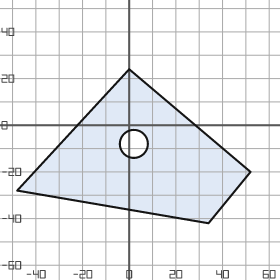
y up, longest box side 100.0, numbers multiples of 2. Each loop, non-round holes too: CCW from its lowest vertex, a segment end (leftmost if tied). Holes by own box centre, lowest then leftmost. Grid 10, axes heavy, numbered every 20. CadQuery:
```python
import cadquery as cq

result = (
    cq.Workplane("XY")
    .moveTo(34.0, -42.0)
    .lineTo(52.0, -20.0)
    .lineTo(0.0, 24.0)
    .lineTo(-48.0, -28.0)
    .close()
    .moveTo(2.0, -8.0)
    .circle(6.0)
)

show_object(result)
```